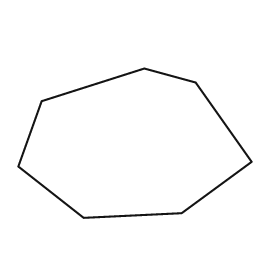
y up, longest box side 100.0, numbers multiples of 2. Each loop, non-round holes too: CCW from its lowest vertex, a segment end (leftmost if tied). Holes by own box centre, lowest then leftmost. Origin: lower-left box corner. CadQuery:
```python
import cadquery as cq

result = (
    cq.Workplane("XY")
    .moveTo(28.0, 0.0)
    .lineTo(70.0, 2.0)
    .lineTo(100.0, 24.0)
    .lineTo(76.0, 58.0)
    .lineTo(54.0, 64.0)
    .lineTo(10.0, 50.0)
    .lineTo(0.0, 22.0)
    .close()
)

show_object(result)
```